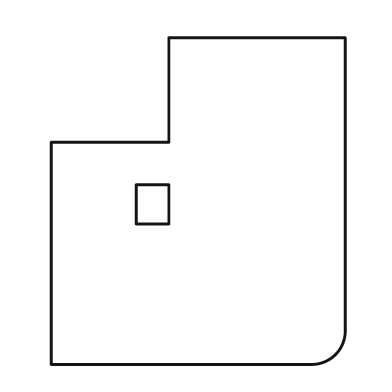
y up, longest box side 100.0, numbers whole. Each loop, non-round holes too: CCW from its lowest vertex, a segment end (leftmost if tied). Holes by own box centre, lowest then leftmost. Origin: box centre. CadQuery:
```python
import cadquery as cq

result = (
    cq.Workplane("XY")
    .moveTo(-45.0, -50.0)
    .lineTo(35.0, -50.0)
    .threePointArc((42.0, -47.0), (45.0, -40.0))
    .lineTo(45.0, 50.0)
    .lineTo(-9.0, 50.0)
    .lineTo(-9.0, 18.0)
    .lineTo(-45.0, 18.0)
    .close()
    .moveTo(-19.0, -7.0)
    .lineTo(-9.0, -7.0)
    .lineTo(-9.0, 5.0)
    .lineTo(-19.0, 5.0)
    .close()
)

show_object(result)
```